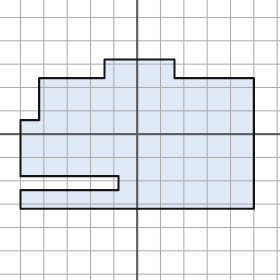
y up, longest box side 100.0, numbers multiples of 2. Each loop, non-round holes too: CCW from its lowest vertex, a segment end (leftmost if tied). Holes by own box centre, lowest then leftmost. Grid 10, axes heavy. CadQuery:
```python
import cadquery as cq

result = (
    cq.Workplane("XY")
    .moveTo(-50.0, -32.0)
    .lineTo(50.0, -32.0)
    .lineTo(50.0, 24.0)
    .lineTo(16.0, 24.0)
    .lineTo(16.0, 32.0)
    .lineTo(-14.0, 32.0)
    .lineTo(-14.0, 24.0)
    .lineTo(-42.0, 24.0)
    .lineTo(-42.0, 6.0)
    .lineTo(-50.0, 6.0)
    .lineTo(-50.0, -18.0)
    .lineTo(-8.0, -18.0)
    .lineTo(-8.0, -24.0)
    .lineTo(-50.0, -24.0)
    .close()
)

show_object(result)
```